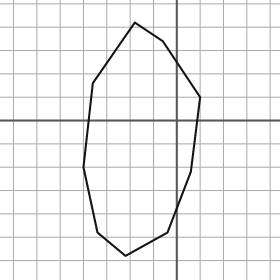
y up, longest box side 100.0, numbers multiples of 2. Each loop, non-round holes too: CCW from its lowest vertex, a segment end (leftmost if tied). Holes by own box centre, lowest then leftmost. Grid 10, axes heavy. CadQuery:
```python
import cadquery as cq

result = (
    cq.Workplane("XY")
    .moveTo(-22.0, -58.0)
    .lineTo(-4.0, -48.0)
    .lineTo(6.0, -22.0)
    .lineTo(10.0, 10.0)
    .lineTo(-6.0, 34.0)
    .lineTo(-18.0, 42.0)
    .lineTo(-36.0, 16.0)
    .lineTo(-40.0, -20.0)
    .lineTo(-34.0, -48.0)
    .close()
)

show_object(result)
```